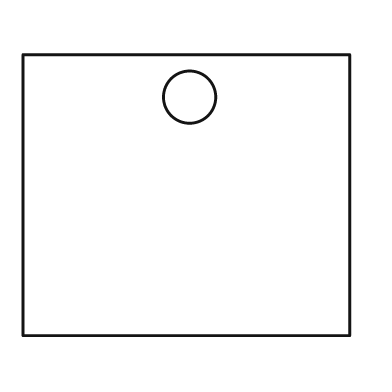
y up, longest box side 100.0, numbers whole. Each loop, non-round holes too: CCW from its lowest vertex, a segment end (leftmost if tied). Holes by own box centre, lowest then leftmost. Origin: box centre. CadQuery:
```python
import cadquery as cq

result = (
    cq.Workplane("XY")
    .moveTo(-50.0, -43.0)
    .lineTo(50.0, -43.0)
    .lineTo(50.0, 43.0)
    .lineTo(-50.0, 43.0)
    .close()
    .moveTo(1.0, 30.0)
    .circle(8.0)
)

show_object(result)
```